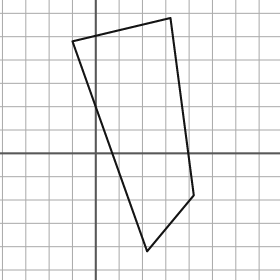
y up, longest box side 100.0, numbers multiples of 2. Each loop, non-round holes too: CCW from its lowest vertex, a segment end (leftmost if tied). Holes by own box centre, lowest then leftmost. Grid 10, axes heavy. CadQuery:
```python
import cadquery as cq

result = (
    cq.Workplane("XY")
    .moveTo(22.0, -42.0)
    .lineTo(42.0, -18.0)
    .lineTo(32.0, 58.0)
    .lineTo(-10.0, 48.0)
    .close()
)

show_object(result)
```